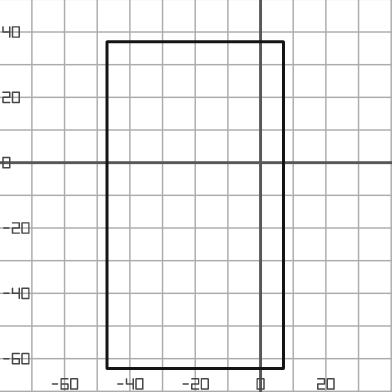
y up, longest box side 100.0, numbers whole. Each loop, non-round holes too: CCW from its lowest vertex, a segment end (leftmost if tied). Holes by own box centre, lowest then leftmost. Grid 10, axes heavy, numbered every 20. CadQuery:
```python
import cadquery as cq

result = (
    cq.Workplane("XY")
    .moveTo(-47.0, -63.0)
    .lineTo(7.0, -63.0)
    .lineTo(7.0, 37.0)
    .lineTo(-47.0, 37.0)
    .close()
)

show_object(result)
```